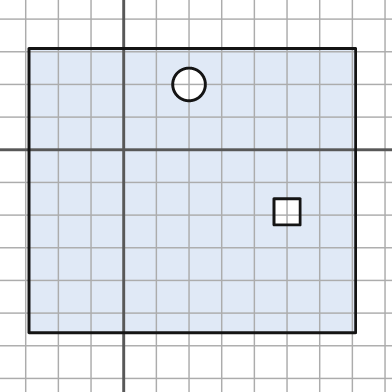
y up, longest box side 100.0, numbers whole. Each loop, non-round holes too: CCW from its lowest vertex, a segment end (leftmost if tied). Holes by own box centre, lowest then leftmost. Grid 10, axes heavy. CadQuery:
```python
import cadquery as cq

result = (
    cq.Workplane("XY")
    .moveTo(-29.0, -56.0)
    .lineTo(71.0, -56.0)
    .lineTo(71.0, 31.0)
    .lineTo(-29.0, 31.0)
    .close()
    .moveTo(46.0, -23.0)
    .lineTo(54.0, -23.0)
    .lineTo(54.0, -15.0)
    .lineTo(46.0, -15.0)
    .close()
    .moveTo(20.0, 20.0)
    .circle(5.0)
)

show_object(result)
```